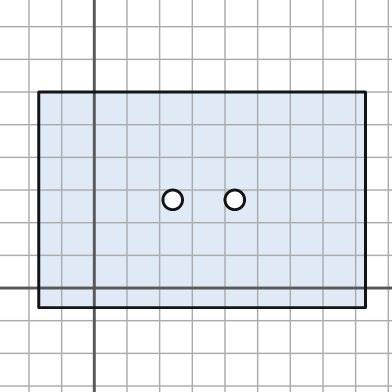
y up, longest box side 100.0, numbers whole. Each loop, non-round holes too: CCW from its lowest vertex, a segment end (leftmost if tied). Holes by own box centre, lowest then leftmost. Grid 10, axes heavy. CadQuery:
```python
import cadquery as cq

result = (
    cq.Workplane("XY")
    .moveTo(-17.0, -6.0)
    .lineTo(83.0, -6.0)
    .lineTo(83.0, 60.0)
    .lineTo(-17.0, 60.0)
    .close()
    .moveTo(24.0, 27.0)
    .circle(3.0)
    .moveTo(43.0, 27.0)
    .circle(3.0)
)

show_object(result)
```